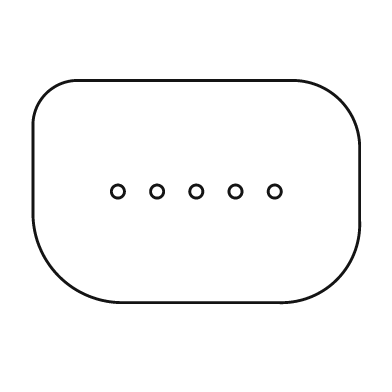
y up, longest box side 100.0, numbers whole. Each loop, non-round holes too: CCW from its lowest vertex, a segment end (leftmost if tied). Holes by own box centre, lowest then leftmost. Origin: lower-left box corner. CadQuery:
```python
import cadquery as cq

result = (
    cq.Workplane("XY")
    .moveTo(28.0, 0.0)
    .lineTo(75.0, 0.0)
    .threePointArc((93.0, 7.0), (100.0, 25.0))
    .lineTo(100.0, 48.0)
    .threePointArc((94.0, 62.0), (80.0, 68.0))
    .lineTo(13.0, 68.0)
    .threePointArc((4.0, 64.0), (0.0, 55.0))
    .lineTo(0.0, 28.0)
    .threePointArc((8.0, 8.0), (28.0, 0.0))
    .close()
    .moveTo(26.0, 34.0)
    .circle(2.0)
    .moveTo(38.0, 34.0)
    .circle(2.0)
    .moveTo(50.0, 34.0)
    .circle(2.0)
    .moveTo(62.0, 34.0)
    .circle(2.0)
    .moveTo(74.0, 34.0)
    .circle(2.0)
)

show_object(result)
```